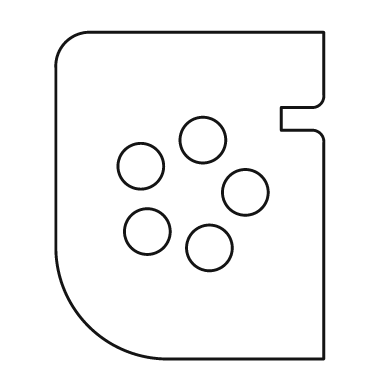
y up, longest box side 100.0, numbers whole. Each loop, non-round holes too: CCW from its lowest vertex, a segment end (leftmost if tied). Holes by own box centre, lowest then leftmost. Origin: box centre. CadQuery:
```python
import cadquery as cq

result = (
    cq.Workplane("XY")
    .moveTo(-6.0, -50.0)
    .lineTo(41.0, -50.0)
    .lineTo(41.0, 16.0)
    .threePointArc((40.0, 19.0), (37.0, 20.0))
    .lineTo(28.0, 20.0)
    .lineTo(28.0, 27.0)
    .lineTo(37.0, 27.0)
    .threePointArc((40.0, 28.0), (41.0, 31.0))
    .lineTo(41.0, 50.0)
    .lineTo(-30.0, 50.0)
    .threePointArc((-38.0, 47.0), (-41.0, 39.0))
    .lineTo(-41.0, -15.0)
    .threePointArc((-31.0, -40.0), (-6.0, -50.0))
    .close()
    .moveTo(6.0, -16.0)
    .circle(7.0)
    .moveTo(-13.0, -11.0)
    .circle(7.0)
    .moveTo(17.0, 1.0)
    .circle(7.0)
    .moveTo(-15.0, 9.0)
    .circle(7.0)
    .moveTo(4.0, 17.0)
    .circle(7.0)
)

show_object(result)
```